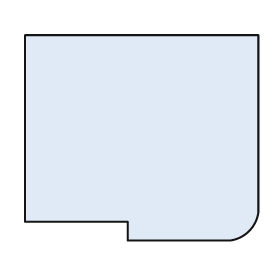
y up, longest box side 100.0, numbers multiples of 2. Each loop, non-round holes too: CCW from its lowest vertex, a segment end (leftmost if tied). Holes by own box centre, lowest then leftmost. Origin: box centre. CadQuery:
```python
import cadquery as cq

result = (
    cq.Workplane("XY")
    .moveTo(-6.0, -44.0)
    .lineTo(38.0, -44.0)
    .threePointArc((46.0, -40.0), (50.0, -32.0))
    .lineTo(50.0, 44.0)
    .lineTo(-50.0, 44.0)
    .lineTo(-50.0, -36.0)
    .lineTo(-6.0, -36.0)
    .close()
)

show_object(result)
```